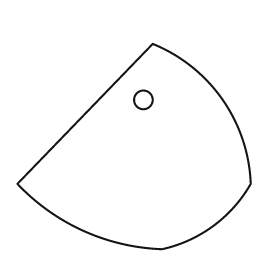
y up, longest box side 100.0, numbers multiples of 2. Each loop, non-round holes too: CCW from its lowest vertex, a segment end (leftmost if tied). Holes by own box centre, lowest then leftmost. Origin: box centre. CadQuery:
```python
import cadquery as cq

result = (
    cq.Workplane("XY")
    .moveTo(12.0, -44.0)
    .threePointArc((34.0, -34.0), (50.0, -16.0))
    .threePointArc((38.0, 20.0), (8.0, 44.0))
    .lineTo(-50.0, -16.0)
    .threePointArc((-22.0, -36.0), (12.0, -44.0))
    .close()
    .moveTo(4.0, 20.0)
    .circle(4.0)
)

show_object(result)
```